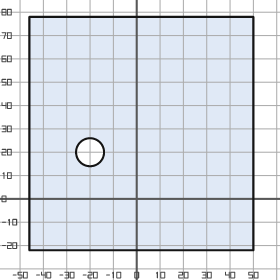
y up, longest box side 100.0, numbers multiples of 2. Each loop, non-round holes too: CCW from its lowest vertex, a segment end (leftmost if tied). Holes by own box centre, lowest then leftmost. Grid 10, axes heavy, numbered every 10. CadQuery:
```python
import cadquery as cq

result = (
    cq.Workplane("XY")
    .moveTo(-46.0, -22.0)
    .lineTo(50.0, -22.0)
    .lineTo(50.0, 78.0)
    .lineTo(-46.0, 78.0)
    .close()
    .moveTo(-20.0, 20.0)
    .circle(6.0)
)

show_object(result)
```